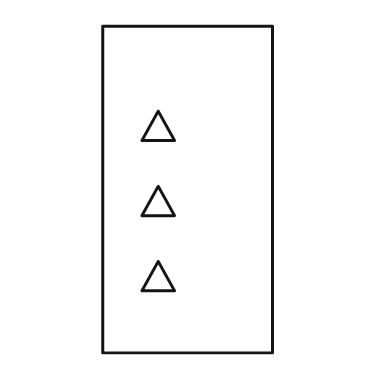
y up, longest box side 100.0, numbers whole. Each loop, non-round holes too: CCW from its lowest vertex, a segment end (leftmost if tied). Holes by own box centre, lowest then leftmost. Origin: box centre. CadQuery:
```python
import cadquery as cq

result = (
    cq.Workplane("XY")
    .moveTo(-26.0, -50.0)
    .lineTo(26.0, -50.0)
    .lineTo(26.0, 50.0)
    .lineTo(-26.0, 50.0)
    .close()
    .moveTo(-14.0, -31.0)
    .lineTo(-4.0, -31.0)
    .lineTo(-9.0, -22.0)
    .close()
    .moveTo(-14.0, -8.0)
    .lineTo(-4.0, -8.0)
    .lineTo(-9.0, 1.0)
    .close()
    .moveTo(-14.0, 15.0)
    .lineTo(-4.0, 15.0)
    .lineTo(-9.0, 24.0)
    .close()
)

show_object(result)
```